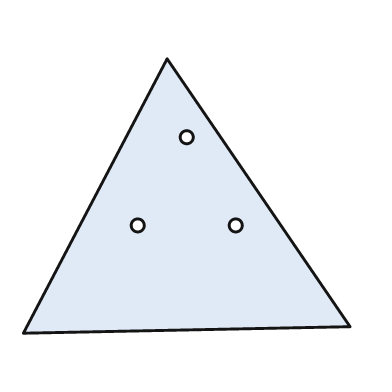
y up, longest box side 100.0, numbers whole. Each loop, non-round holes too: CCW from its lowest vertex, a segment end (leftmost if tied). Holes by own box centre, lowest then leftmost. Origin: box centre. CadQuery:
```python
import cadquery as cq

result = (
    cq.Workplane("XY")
    .moveTo(-50.0, -42.0)
    .lineTo(50.0, -40.0)
    .lineTo(-6.0, 42.0)
    .close()
    .moveTo(-15.0, -9.0)
    .circle(2.0)
    .moveTo(15.0, -9.0)
    .circle(2.0)
    .moveTo(0.0, 18.0)
    .circle(2.0)
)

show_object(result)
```